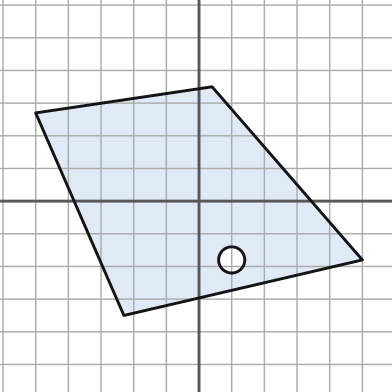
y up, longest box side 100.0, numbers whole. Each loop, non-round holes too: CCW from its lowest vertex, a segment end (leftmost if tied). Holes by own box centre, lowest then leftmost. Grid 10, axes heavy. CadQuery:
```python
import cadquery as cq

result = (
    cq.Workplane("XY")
    .moveTo(-23.0, -35.0)
    .lineTo(50.0, -18.0)
    .lineTo(4.0, 35.0)
    .lineTo(-50.0, 27.0)
    .close()
    .moveTo(10.0, -18.0)
    .circle(4.0)
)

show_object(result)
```